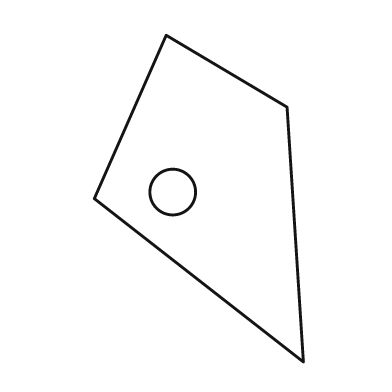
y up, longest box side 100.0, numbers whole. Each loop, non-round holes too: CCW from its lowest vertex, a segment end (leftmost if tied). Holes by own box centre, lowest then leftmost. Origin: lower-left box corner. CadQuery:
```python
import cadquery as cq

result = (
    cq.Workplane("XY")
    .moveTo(64.0, 0.0)
    .lineTo(59.0, 78.0)
    .lineTo(22.0, 100.0)
    .lineTo(0.0, 50.0)
    .close()
    .moveTo(24.0, 52.0)
    .circle(7.0)
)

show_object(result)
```